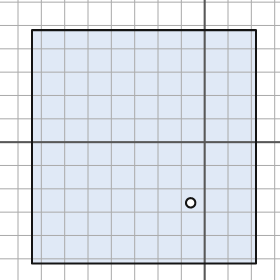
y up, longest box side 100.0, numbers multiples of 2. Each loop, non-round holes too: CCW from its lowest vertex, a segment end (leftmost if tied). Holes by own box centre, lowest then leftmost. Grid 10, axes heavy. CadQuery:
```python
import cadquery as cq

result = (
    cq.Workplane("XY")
    .moveTo(-74.0, -52.0)
    .lineTo(22.0, -52.0)
    .lineTo(22.0, 48.0)
    .lineTo(-74.0, 48.0)
    .close()
    .moveTo(-6.0, -26.0)
    .circle(2.0)
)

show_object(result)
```